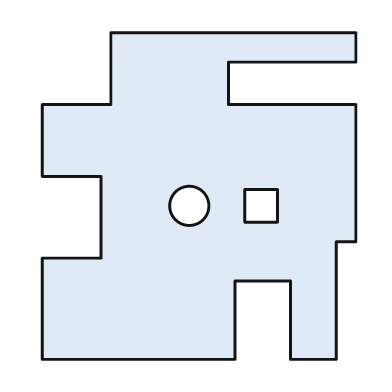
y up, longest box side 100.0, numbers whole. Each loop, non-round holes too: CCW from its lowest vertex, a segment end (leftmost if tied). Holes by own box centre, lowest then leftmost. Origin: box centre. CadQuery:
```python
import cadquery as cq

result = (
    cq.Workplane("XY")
    .moveTo(-48.0, -50.0)
    .lineTo(11.0, -50.0)
    .lineTo(11.0, -26.0)
    .lineTo(28.0, -26.0)
    .lineTo(28.0, -50.0)
    .lineTo(42.0, -50.0)
    .lineTo(42.0, -14.0)
    .lineTo(48.0, -14.0)
    .lineTo(48.0, 28.0)
    .lineTo(9.0, 28.0)
    .lineTo(9.0, 41.0)
    .lineTo(48.0, 41.0)
    .lineTo(48.0, 50.0)
    .lineTo(-27.0, 50.0)
    .lineTo(-27.0, 28.0)
    .lineTo(-48.0, 28.0)
    .lineTo(-48.0, 6.0)
    .lineTo(-30.0, 6.0)
    .lineTo(-30.0, -19.0)
    .lineTo(-48.0, -19.0)
    .close()
    .moveTo(-3.0, -3.0)
    .circle(6.0)
    .moveTo(14.0, -8.0)
    .lineTo(24.0, -8.0)
    .lineTo(24.0, 2.0)
    .lineTo(14.0, 2.0)
    .close()
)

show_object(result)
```